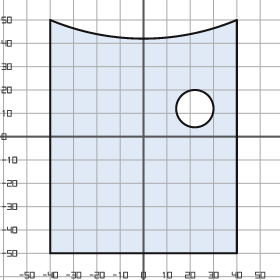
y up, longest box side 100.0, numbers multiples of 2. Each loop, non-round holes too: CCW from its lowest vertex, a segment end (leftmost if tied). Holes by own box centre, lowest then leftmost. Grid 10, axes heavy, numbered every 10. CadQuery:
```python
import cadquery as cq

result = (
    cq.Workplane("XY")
    .moveTo(-40.0, -50.0)
    .lineTo(40.0, -50.0)
    .lineTo(40.0, 50.0)
    .threePointArc((0.0, 42.0), (-40.0, 50.0))
    .close()
    .moveTo(22.0, 12.0)
    .circle(8.0)
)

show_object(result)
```